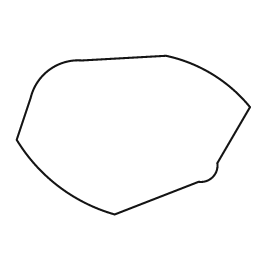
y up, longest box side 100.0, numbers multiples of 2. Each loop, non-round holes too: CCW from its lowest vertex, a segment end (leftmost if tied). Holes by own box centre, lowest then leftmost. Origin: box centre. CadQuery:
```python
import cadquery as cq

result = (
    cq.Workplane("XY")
    .moveTo(-8.0, -34.0)
    .lineTo(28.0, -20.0)
    .threePointArc((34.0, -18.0), (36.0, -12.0))
    .lineTo(50.0, 12.0)
    .threePointArc((34.0, 26.0), (14.0, 34.0))
    .lineTo(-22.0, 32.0)
    .threePointArc((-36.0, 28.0), (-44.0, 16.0))
    .lineTo(-50.0, -2.0)
    .threePointArc((-32.0, -22.0), (-8.0, -34.0))
    .close()
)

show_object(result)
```